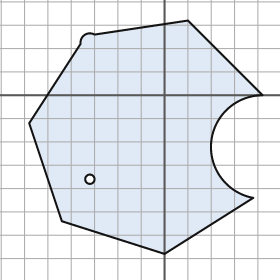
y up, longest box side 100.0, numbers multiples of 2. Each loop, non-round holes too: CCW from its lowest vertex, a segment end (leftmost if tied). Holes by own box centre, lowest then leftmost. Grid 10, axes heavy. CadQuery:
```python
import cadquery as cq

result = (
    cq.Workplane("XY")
    .moveTo(0.0, -68.0)
    .lineTo(38.0, -44.0)
    .threePointArc((20.0, -20.0), (42.0, 0.0))
    .lineTo(10.0, 32.0)
    .lineTo(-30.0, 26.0)
    .threePointArc((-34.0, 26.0), (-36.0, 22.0))
    .lineTo(-58.0, -12.0)
    .lineTo(-44.0, -54.0)
    .close()
    .moveTo(-32.0, -36.0)
    .circle(2.0)
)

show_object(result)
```